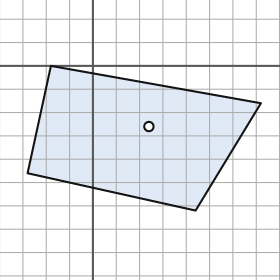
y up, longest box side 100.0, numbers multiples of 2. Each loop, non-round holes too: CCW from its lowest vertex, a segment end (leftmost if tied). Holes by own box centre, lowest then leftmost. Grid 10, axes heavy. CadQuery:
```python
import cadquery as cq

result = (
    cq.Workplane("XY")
    .moveTo(44.0, -62.0)
    .lineTo(72.0, -16.0)
    .lineTo(-18.0, 0.0)
    .lineTo(-28.0, -46.0)
    .close()
    .moveTo(24.0, -26.0)
    .circle(2.0)
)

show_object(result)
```